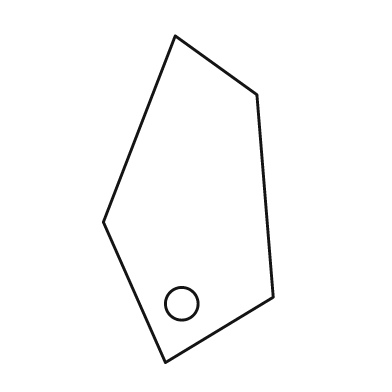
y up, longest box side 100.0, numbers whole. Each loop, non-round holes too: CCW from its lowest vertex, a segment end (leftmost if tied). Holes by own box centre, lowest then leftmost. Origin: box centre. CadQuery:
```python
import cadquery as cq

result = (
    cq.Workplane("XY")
    .moveTo(-7.0, -50.0)
    .lineTo(26.0, -30.0)
    .lineTo(21.0, 32.0)
    .lineTo(-4.0, 50.0)
    .lineTo(-26.0, -7.0)
    .close()
    .moveTo(-2.0, -32.0)
    .circle(5.0)
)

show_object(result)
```